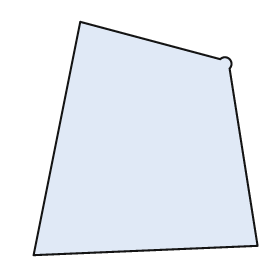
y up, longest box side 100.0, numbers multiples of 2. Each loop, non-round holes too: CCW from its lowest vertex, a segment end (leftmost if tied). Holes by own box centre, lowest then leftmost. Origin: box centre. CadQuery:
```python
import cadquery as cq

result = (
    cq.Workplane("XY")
    .moveTo(-48.0, -50.0)
    .lineTo(48.0, -46.0)
    .lineTo(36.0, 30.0)
    .threePointArc((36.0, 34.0), (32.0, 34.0))
    .lineTo(-28.0, 50.0)
    .close()
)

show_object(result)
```